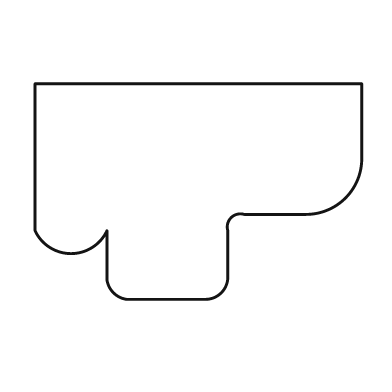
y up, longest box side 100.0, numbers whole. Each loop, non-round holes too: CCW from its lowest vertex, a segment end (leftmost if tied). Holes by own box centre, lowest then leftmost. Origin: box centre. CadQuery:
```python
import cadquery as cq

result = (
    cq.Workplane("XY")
    .moveTo(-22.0, -33.0)
    .lineTo(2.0, -33.0)
    .threePointArc((7.0, -31.0), (9.0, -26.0))
    .lineTo(9.0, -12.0)
    .threePointArc((10.0, -8.0), (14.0, -7.0))
    .lineTo(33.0, -7.0)
    .threePointArc((45.0, -2.0), (50.0, 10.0))
    .lineTo(50.0, 33.0)
    .lineTo(-50.0, 33.0)
    .lineTo(-50.0, -12.0)
    .threePointArc((-39.0, -19.0), (-28.0, -12.0))
    .lineTo(-28.0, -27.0)
    .threePointArc((-26.0, -31.0), (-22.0, -33.0))
    .close()
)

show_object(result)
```